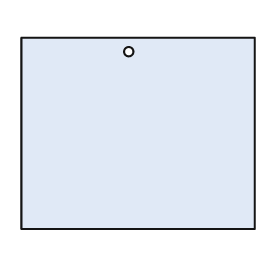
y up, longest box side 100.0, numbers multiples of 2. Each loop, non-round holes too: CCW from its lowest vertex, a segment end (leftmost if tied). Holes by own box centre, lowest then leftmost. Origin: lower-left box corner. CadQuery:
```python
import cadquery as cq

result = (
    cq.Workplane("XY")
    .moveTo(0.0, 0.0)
    .lineTo(100.0, 0.0)
    .lineTo(100.0, 82.0)
    .lineTo(0.0, 82.0)
    .close()
    .moveTo(46.0, 76.0)
    .circle(2.0)
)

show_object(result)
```